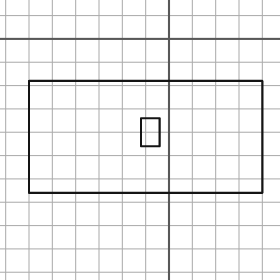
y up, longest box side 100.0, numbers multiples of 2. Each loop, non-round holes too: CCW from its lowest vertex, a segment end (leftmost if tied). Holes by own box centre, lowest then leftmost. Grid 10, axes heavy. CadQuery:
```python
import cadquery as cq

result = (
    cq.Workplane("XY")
    .moveTo(-60.0, -66.0)
    .lineTo(40.0, -66.0)
    .lineTo(40.0, -18.0)
    .lineTo(-60.0, -18.0)
    .close()
    .moveTo(-12.0, -46.0)
    .lineTo(-4.0, -46.0)
    .lineTo(-4.0, -34.0)
    .lineTo(-12.0, -34.0)
    .close()
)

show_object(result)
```